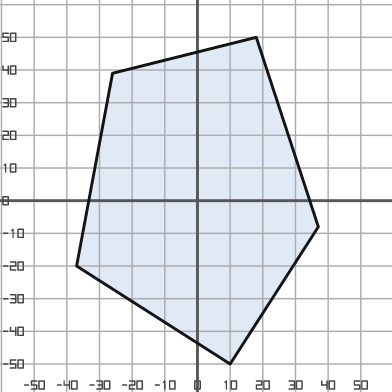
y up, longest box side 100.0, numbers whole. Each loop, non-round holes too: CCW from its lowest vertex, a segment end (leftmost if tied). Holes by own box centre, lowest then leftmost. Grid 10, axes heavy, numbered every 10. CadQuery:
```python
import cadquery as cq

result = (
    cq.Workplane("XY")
    .moveTo(10.0, -50.0)
    .lineTo(37.0, -8.0)
    .lineTo(18.0, 50.0)
    .lineTo(-26.0, 39.0)
    .lineTo(-37.0, -20.0)
    .close()
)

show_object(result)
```